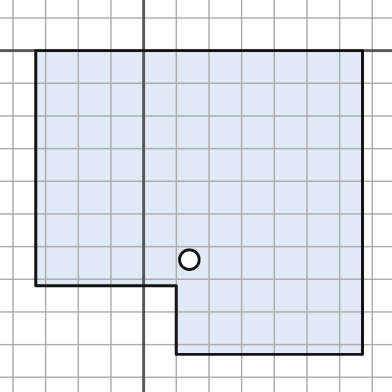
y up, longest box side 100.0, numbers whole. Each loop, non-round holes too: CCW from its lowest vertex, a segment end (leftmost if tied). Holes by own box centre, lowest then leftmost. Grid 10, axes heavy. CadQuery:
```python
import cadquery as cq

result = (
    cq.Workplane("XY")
    .moveTo(10.0, -93.0)
    .lineTo(67.0, -93.0)
    .lineTo(67.0, 0.0)
    .lineTo(-33.0, 0.0)
    .lineTo(-33.0, -72.0)
    .lineTo(10.0, -72.0)
    .close()
    .moveTo(14.0, -64.0)
    .circle(3.0)
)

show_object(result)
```